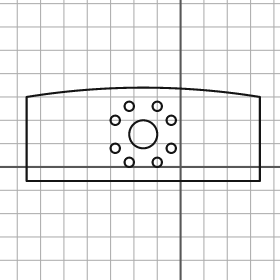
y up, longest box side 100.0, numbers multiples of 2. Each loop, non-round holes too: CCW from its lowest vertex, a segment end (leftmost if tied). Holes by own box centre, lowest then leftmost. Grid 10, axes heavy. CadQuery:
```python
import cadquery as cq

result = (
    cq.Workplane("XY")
    .moveTo(-66.0, -6.0)
    .lineTo(34.0, -6.0)
    .lineTo(34.0, 30.0)
    .threePointArc((-16.0, 34.0), (-66.0, 30.0))
    .close()
    .moveTo(-22.0, 2.0)
    .circle(2.0)
    .moveTo(-10.0, 2.0)
    .circle(2.0)
    .moveTo(-28.0, 8.0)
    .circle(2.0)
    .moveTo(-4.0, 8.0)
    .circle(2.0)
    .moveTo(-16.0, 14.0)
    .circle(6.0)
    .moveTo(-28.0, 20.0)
    .circle(2.0)
    .moveTo(-4.0, 20.0)
    .circle(2.0)
    .moveTo(-22.0, 26.0)
    .circle(2.0)
    .moveTo(-10.0, 26.0)
    .circle(2.0)
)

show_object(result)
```